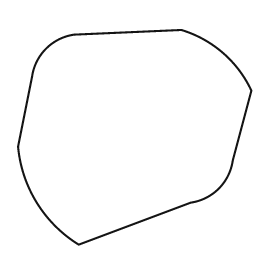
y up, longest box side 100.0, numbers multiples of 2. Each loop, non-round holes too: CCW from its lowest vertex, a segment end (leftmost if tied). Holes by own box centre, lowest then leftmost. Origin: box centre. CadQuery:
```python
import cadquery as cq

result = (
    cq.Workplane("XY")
    .moveTo(-24.0, -46.0)
    .lineTo(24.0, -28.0)
    .threePointArc((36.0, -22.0), (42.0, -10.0))
    .lineTo(50.0, 20.0)
    .threePointArc((38.0, 36.0), (20.0, 46.0))
    .lineTo(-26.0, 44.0)
    .threePointArc((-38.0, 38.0), (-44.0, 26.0))
    .lineTo(-50.0, -4.0)
    .threePointArc((-42.0, -28.0), (-24.0, -46.0))
    .close()
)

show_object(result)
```